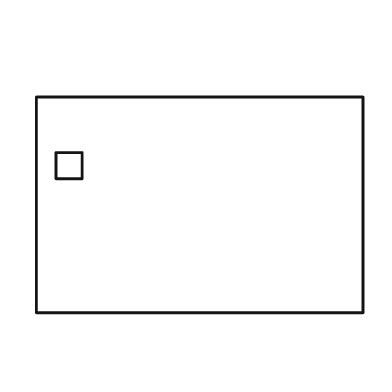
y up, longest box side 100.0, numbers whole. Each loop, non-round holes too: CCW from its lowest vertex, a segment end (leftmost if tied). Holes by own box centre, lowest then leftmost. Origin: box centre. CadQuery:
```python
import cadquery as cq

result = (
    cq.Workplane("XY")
    .moveTo(-50.0, -33.0)
    .lineTo(50.0, -33.0)
    .lineTo(50.0, 33.0)
    .lineTo(-50.0, 33.0)
    .close()
    .moveTo(-44.0, 8.0)
    .lineTo(-36.0, 8.0)
    .lineTo(-36.0, 16.0)
    .lineTo(-44.0, 16.0)
    .close()
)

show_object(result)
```